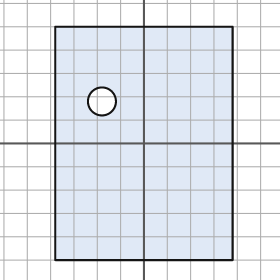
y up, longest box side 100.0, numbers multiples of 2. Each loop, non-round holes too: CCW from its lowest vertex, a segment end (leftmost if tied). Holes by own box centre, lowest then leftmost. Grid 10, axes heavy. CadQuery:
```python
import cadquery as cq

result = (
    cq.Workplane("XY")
    .moveTo(-38.0, -50.0)
    .lineTo(38.0, -50.0)
    .lineTo(38.0, 50.0)
    .lineTo(-38.0, 50.0)
    .close()
    .moveTo(-18.0, 18.0)
    .circle(6.0)
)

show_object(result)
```